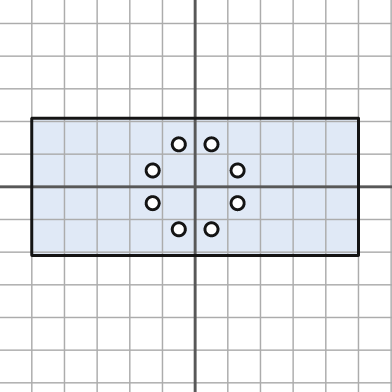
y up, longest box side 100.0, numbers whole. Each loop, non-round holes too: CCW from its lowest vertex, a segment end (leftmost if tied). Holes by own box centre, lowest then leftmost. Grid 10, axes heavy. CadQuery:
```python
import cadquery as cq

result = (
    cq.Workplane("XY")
    .moveTo(-50.0, -21.0)
    .lineTo(50.0, -21.0)
    .lineTo(50.0, 21.0)
    .lineTo(-50.0, 21.0)
    .close()
    .moveTo(-5.0, -13.0)
    .circle(2.0)
    .moveTo(5.0, -13.0)
    .circle(2.0)
    .moveTo(-13.0, -5.0)
    .circle(2.0)
    .moveTo(13.0, -5.0)
    .circle(2.0)
    .moveTo(-13.0, 5.0)
    .circle(2.0)
    .moveTo(13.0, 5.0)
    .circle(2.0)
    .moveTo(-5.0, 13.0)
    .circle(2.0)
    .moveTo(5.0, 13.0)
    .circle(2.0)
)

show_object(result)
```